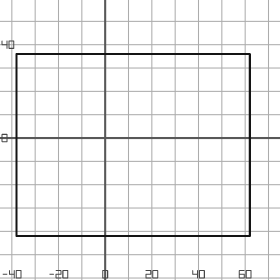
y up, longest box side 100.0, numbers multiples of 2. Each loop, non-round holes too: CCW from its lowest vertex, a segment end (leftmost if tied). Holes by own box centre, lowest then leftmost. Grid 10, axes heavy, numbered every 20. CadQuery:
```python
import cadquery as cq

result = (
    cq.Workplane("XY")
    .moveTo(-38.0, -42.0)
    .lineTo(62.0, -42.0)
    .lineTo(62.0, 36.0)
    .lineTo(-38.0, 36.0)
    .close()
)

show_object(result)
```